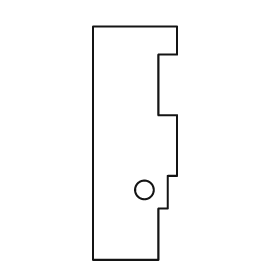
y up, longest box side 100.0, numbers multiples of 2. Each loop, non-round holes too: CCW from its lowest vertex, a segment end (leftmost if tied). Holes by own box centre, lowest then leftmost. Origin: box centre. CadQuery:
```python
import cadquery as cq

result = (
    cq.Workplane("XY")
    .moveTo(-18.0, -50.0)
    .lineTo(10.0, -50.0)
    .lineTo(10.0, -28.0)
    .lineTo(14.0, -28.0)
    .lineTo(14.0, -14.0)
    .lineTo(18.0, -14.0)
    .lineTo(18.0, 12.0)
    .lineTo(10.0, 12.0)
    .lineTo(10.0, 38.0)
    .lineTo(18.0, 38.0)
    .lineTo(18.0, 50.0)
    .lineTo(-18.0, 50.0)
    .close()
    .moveTo(4.0, -20.0)
    .circle(4.0)
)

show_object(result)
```